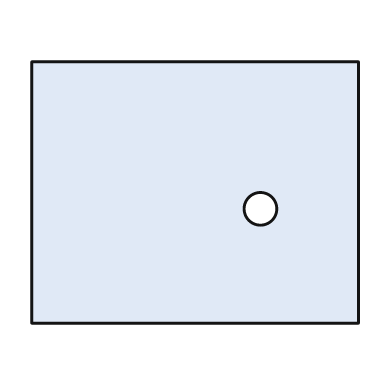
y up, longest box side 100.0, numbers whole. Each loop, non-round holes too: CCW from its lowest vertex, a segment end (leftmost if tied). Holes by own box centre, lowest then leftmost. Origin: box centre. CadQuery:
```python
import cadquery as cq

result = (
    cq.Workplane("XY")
    .moveTo(-50.0, -40.0)
    .lineTo(50.0, -40.0)
    .lineTo(50.0, 40.0)
    .lineTo(-50.0, 40.0)
    .close()
    .moveTo(20.0, -5.0)
    .circle(5.0)
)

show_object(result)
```